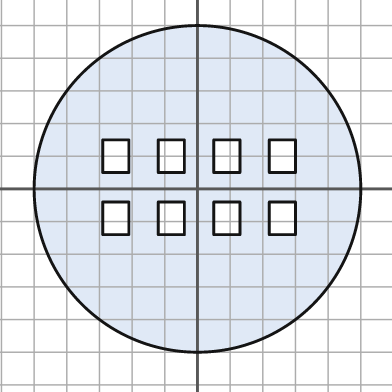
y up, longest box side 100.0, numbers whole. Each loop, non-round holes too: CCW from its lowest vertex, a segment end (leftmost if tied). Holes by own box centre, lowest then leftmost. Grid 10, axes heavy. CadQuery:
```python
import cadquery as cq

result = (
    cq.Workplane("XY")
    .moveTo(0.0, 0.0)
    .circle(50.0)
    .moveTo(-29.0, -14.0)
    .lineTo(-21.0, -14.0)
    .lineTo(-21.0, -4.0)
    .lineTo(-29.0, -4.0)
    .close()
    .moveTo(-12.0, -14.0)
    .lineTo(-4.0, -14.0)
    .lineTo(-4.0, -4.0)
    .lineTo(-12.0, -4.0)
    .close()
    .moveTo(5.0, -14.0)
    .lineTo(13.0, -14.0)
    .lineTo(13.0, -4.0)
    .lineTo(5.0, -4.0)
    .close()
    .moveTo(22.0, -14.0)
    .lineTo(30.0, -14.0)
    .lineTo(30.0, -4.0)
    .lineTo(22.0, -4.0)
    .close()
    .moveTo(-29.0, 5.0)
    .lineTo(-21.0, 5.0)
    .lineTo(-21.0, 15.0)
    .lineTo(-29.0, 15.0)
    .close()
    .moveTo(-12.0, 5.0)
    .lineTo(-4.0, 5.0)
    .lineTo(-4.0, 15.0)
    .lineTo(-12.0, 15.0)
    .close()
    .moveTo(5.0, 5.0)
    .lineTo(13.0, 5.0)
    .lineTo(13.0, 15.0)
    .lineTo(5.0, 15.0)
    .close()
    .moveTo(22.0, 5.0)
    .lineTo(30.0, 5.0)
    .lineTo(30.0, 15.0)
    .lineTo(22.0, 15.0)
    .close()
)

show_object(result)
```